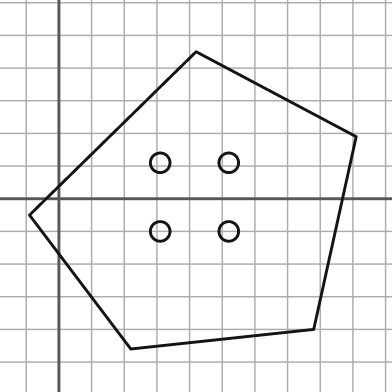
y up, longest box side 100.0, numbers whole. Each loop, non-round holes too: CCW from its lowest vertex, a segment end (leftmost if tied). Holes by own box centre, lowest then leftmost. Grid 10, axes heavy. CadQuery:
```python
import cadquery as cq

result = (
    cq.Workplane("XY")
    .moveTo(22.0, -46.0)
    .lineTo(78.0, -40.0)
    .lineTo(91.0, 19.0)
    .lineTo(42.0, 45.0)
    .lineTo(-9.0, -5.0)
    .close()
    .moveTo(31.0, -10.0)
    .circle(3.0)
    .moveTo(52.0, -10.0)
    .circle(3.0)
    .moveTo(31.0, 11.0)
    .circle(3.0)
    .moveTo(52.0, 11.0)
    .circle(3.0)
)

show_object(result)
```